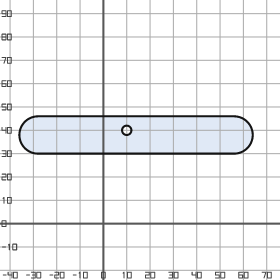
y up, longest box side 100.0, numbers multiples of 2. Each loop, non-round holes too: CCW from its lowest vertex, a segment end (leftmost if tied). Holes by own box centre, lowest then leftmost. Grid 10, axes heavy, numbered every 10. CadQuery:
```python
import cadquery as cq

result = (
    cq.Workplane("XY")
    .moveTo(-28.0, 30.0)
    .lineTo(56.0, 30.0)
    .threePointArc((64.0, 38.0), (56.0, 46.0))
    .lineTo(-28.0, 46.0)
    .threePointArc((-36.0, 38.0), (-28.0, 30.0))
    .close()
    .moveTo(10.0, 40.0)
    .circle(2.0)
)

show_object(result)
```